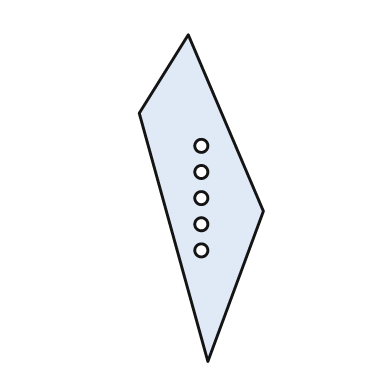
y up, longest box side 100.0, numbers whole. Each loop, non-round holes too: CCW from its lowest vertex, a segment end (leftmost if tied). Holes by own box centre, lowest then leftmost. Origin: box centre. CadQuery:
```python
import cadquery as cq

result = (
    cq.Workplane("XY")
    .moveTo(2.0, -50.0)
    .lineTo(19.0, -4.0)
    .lineTo(-4.0, 50.0)
    .lineTo(-19.0, 26.0)
    .close()
    .moveTo(0.0, -16.0)
    .circle(2.0)
    .moveTo(0.0, -8.0)
    .circle(2.0)
    .moveTo(0.0, 0.0)
    .circle(2.0)
    .moveTo(0.0, 8.0)
    .circle(2.0)
    .moveTo(0.0, 16.0)
    .circle(2.0)
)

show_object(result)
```